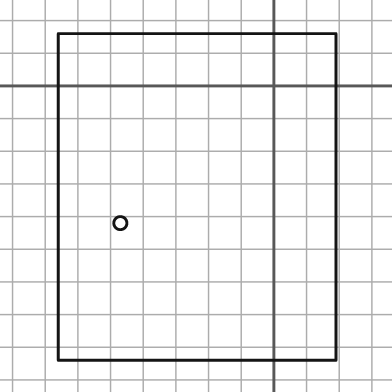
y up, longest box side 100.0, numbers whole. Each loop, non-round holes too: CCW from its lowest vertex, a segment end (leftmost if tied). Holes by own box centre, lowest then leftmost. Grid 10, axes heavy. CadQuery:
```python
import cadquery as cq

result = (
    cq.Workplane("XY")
    .moveTo(-66.0, -84.0)
    .lineTo(19.0, -84.0)
    .lineTo(19.0, 16.0)
    .lineTo(-66.0, 16.0)
    .close()
    .moveTo(-47.0, -42.0)
    .circle(2.0)
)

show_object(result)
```